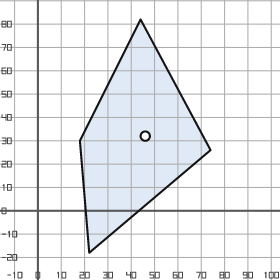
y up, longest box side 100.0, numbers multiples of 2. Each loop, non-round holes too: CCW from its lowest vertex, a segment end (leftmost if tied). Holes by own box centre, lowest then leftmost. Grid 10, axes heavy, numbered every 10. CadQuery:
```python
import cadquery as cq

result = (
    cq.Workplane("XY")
    .moveTo(22.0, -18.0)
    .lineTo(74.0, 26.0)
    .lineTo(44.0, 82.0)
    .lineTo(18.0, 30.0)
    .close()
    .moveTo(46.0, 32.0)
    .circle(2.0)
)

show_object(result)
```